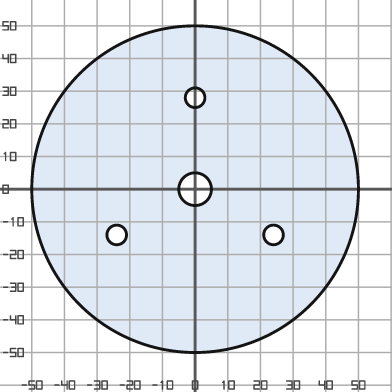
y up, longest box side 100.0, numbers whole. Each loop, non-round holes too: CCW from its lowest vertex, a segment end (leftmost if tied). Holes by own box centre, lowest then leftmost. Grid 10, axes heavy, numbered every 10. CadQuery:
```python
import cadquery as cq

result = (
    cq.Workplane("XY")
    .moveTo(0.0, 0.0)
    .circle(50.0)
    .moveTo(-24.0, -14.0)
    .circle(3.0)
    .moveTo(24.0, -14.0)
    .circle(3.0)
    .moveTo(0.0, 0.0)
    .circle(5.0)
    .moveTo(0.0, 28.0)
    .circle(3.0)
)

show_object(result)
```